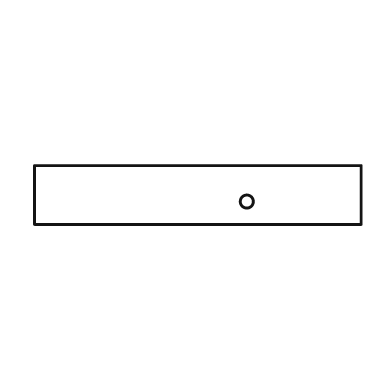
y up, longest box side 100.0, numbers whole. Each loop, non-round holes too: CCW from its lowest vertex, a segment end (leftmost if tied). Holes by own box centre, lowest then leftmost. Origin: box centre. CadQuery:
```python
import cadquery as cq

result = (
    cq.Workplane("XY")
    .moveTo(-50.0, -9.0)
    .lineTo(50.0, -9.0)
    .lineTo(50.0, 9.0)
    .lineTo(-50.0, 9.0)
    .close()
    .moveTo(15.0, -2.0)
    .circle(2.0)
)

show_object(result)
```